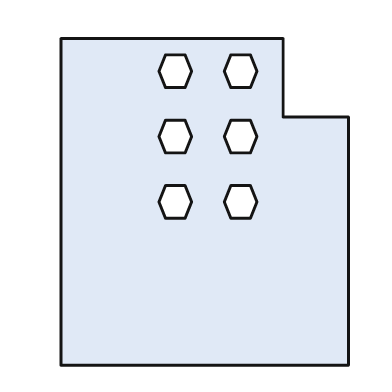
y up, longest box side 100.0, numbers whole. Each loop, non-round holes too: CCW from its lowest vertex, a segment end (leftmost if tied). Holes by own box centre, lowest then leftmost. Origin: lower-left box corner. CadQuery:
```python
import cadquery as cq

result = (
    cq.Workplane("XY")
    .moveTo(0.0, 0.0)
    .lineTo(88.0, 0.0)
    .lineTo(88.0, 76.0)
    .lineTo(68.0, 76.0)
    .lineTo(68.0, 100.0)
    .lineTo(0.0, 100.0)
    .close()
    .moveTo(32.0, 45.0)
    .lineTo(38.0, 45.0)
    .lineTo(40.0, 50.0)
    .lineTo(38.0, 55.0)
    .lineTo(32.0, 55.0)
    .lineTo(30.0, 50.0)
    .close()
    .moveTo(52.0, 45.0)
    .lineTo(58.0, 45.0)
    .lineTo(60.0, 50.0)
    .lineTo(58.0, 55.0)
    .lineTo(52.0, 55.0)
    .lineTo(50.0, 50.0)
    .close()
    .moveTo(32.0, 65.0)
    .lineTo(38.0, 65.0)
    .lineTo(40.0, 70.0)
    .lineTo(38.0, 75.0)
    .lineTo(32.0, 75.0)
    .lineTo(30.0, 70.0)
    .close()
    .moveTo(52.0, 65.0)
    .lineTo(58.0, 65.0)
    .lineTo(60.0, 70.0)
    .lineTo(58.0, 75.0)
    .lineTo(52.0, 75.0)
    .lineTo(50.0, 70.0)
    .close()
    .moveTo(32.0, 85.0)
    .lineTo(38.0, 85.0)
    .lineTo(40.0, 90.0)
    .lineTo(38.0, 95.0)
    .lineTo(32.0, 95.0)
    .lineTo(30.0, 90.0)
    .close()
    .moveTo(52.0, 85.0)
    .lineTo(58.0, 85.0)
    .lineTo(60.0, 90.0)
    .lineTo(58.0, 95.0)
    .lineTo(52.0, 95.0)
    .lineTo(50.0, 90.0)
    .close()
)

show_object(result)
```